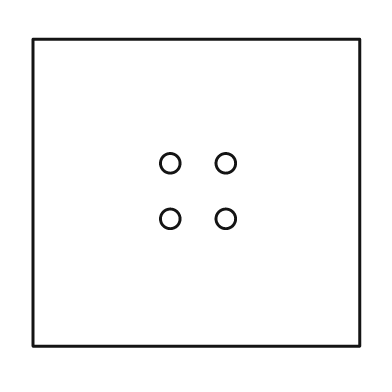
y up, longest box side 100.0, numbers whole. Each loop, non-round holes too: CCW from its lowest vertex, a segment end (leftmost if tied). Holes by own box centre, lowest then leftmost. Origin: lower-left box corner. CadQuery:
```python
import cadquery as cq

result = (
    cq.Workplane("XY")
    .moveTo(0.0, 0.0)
    .lineTo(100.0, 0.0)
    .lineTo(100.0, 94.0)
    .lineTo(0.0, 94.0)
    .close()
    .moveTo(42.0, 39.0)
    .circle(3.0)
    .moveTo(59.0, 39.0)
    .circle(3.0)
    .moveTo(42.0, 56.0)
    .circle(3.0)
    .moveTo(59.0, 56.0)
    .circle(3.0)
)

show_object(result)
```